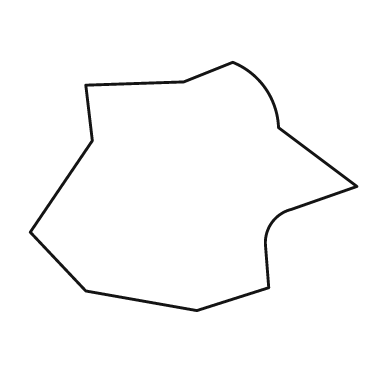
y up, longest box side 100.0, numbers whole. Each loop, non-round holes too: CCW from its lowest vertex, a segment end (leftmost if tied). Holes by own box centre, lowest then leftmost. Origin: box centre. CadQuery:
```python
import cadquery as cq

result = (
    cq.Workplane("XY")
    .moveTo(1.0, -38.0)
    .lineTo(23.0, -31.0)
    .lineTo(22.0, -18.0)
    .threePointArc((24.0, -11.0), (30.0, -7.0))
    .lineTo(50.0, 0.0)
    .lineTo(26.0, 18.0)
    .threePointArc((22.0, 30.0), (12.0, 38.0))
    .lineTo(-3.0, 32.0)
    .lineTo(-33.0, 31.0)
    .lineTo(-31.0, 14.0)
    .lineTo(-50.0, -14.0)
    .lineTo(-33.0, -32.0)
    .close()
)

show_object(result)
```